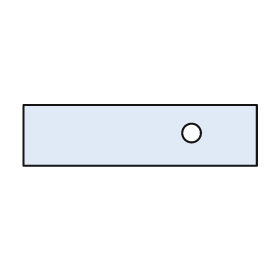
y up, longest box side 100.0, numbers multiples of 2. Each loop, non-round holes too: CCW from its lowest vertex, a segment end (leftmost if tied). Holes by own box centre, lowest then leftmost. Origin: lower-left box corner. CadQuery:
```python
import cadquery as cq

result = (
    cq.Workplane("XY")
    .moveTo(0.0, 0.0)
    .lineTo(100.0, 0.0)
    .lineTo(100.0, 26.0)
    .lineTo(0.0, 26.0)
    .close()
    .moveTo(72.0, 14.0)
    .circle(4.0)
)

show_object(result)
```